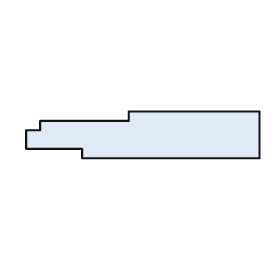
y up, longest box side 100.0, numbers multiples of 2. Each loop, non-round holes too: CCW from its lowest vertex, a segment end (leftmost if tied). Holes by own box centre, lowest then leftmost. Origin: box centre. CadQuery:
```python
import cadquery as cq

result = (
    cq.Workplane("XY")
    .moveTo(-26.0, -10.0)
    .lineTo(50.0, -10.0)
    .lineTo(50.0, 10.0)
    .lineTo(-6.0, 10.0)
    .lineTo(-6.0, 6.0)
    .lineTo(-44.0, 6.0)
    .lineTo(-44.0, 2.0)
    .lineTo(-50.0, 2.0)
    .lineTo(-50.0, -6.0)
    .lineTo(-26.0, -6.0)
    .close()
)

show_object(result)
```